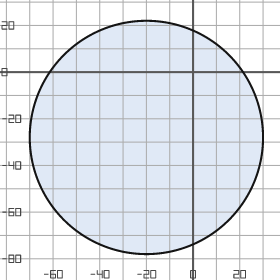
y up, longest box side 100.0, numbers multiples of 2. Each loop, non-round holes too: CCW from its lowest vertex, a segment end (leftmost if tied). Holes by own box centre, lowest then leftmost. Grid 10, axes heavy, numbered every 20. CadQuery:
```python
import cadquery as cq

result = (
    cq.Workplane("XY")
    .moveTo(-20.0, -28.0)
    .circle(50.0)
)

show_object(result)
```